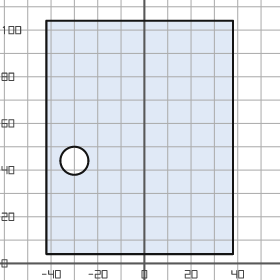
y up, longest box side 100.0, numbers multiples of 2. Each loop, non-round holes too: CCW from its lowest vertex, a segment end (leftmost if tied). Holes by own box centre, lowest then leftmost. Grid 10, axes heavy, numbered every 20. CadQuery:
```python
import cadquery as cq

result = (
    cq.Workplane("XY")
    .moveTo(-42.0, 4.0)
    .lineTo(38.0, 4.0)
    .lineTo(38.0, 104.0)
    .lineTo(-42.0, 104.0)
    .close()
    .moveTo(-30.0, 44.0)
    .circle(6.0)
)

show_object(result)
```